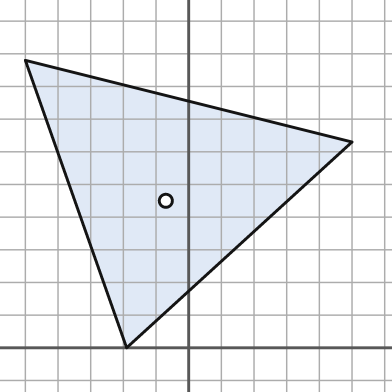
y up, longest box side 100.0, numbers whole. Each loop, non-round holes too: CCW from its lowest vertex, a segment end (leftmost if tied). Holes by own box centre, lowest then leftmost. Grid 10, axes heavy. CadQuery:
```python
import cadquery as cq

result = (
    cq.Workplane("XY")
    .moveTo(-19.0, 0.0)
    .lineTo(50.0, 63.0)
    .lineTo(-50.0, 88.0)
    .close()
    .moveTo(-7.0, 45.0)
    .circle(2.0)
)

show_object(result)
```